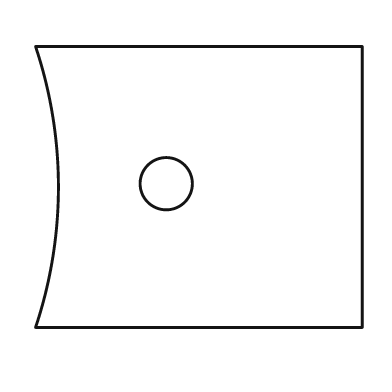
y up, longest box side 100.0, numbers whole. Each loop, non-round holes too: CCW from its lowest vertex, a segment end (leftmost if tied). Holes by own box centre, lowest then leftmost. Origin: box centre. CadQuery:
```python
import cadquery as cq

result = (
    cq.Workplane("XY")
    .moveTo(-50.0, -43.0)
    .lineTo(50.0, -43.0)
    .lineTo(50.0, 43.0)
    .lineTo(-50.0, 43.0)
    .threePointArc((-43.0, 0.0), (-50.0, -43.0))
    .close()
    .moveTo(-10.0, 1.0)
    .circle(8.0)
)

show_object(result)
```